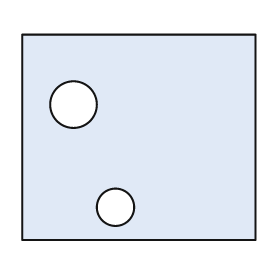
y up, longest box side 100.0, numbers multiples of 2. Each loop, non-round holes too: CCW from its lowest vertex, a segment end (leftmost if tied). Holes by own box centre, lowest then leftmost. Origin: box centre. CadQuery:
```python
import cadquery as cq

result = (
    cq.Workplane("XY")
    .moveTo(-50.0, -44.0)
    .lineTo(50.0, -44.0)
    .lineTo(50.0, 44.0)
    .lineTo(-50.0, 44.0)
    .close()
    .moveTo(-10.0, -30.0)
    .circle(8.0)
    .moveTo(-28.0, 14.0)
    .circle(10.0)
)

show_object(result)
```